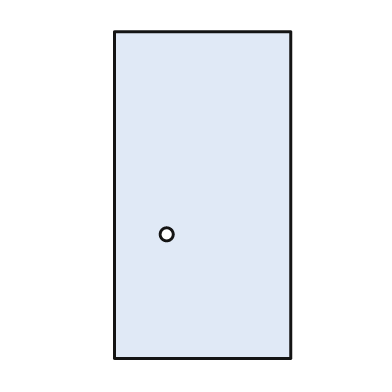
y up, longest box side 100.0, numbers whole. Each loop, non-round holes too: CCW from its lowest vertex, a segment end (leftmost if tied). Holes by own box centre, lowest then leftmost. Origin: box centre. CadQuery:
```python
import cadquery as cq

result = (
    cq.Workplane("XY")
    .moveTo(-27.0, -50.0)
    .lineTo(27.0, -50.0)
    .lineTo(27.0, 50.0)
    .lineTo(-27.0, 50.0)
    .close()
    .moveTo(-11.0, -12.0)
    .circle(2.0)
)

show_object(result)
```